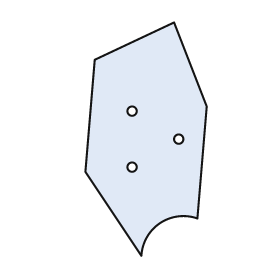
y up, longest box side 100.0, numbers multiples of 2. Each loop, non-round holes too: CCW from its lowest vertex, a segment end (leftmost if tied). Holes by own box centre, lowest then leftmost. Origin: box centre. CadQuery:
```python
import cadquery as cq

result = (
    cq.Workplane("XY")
    .moveTo(-2.0, -50.0)
    .threePointArc((6.0, -36.0), (22.0, -34.0))
    .lineTo(26.0, 14.0)
    .lineTo(12.0, 50.0)
    .lineTo(-22.0, 34.0)
    .lineTo(-26.0, -14.0)
    .close()
    .moveTo(-6.0, -12.0)
    .circle(2.0)
    .moveTo(14.0, 0.0)
    .circle(2.0)
    .moveTo(-6.0, 12.0)
    .circle(2.0)
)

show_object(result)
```